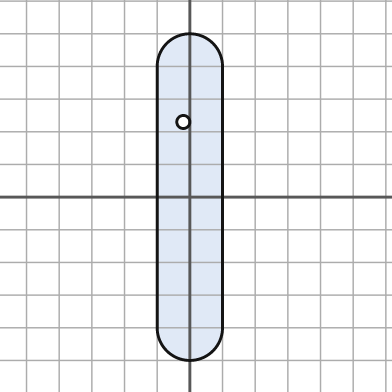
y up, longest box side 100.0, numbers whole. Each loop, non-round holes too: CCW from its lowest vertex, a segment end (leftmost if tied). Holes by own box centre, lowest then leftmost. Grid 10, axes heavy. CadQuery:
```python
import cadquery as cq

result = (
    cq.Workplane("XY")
    .moveTo(-10.0, -40.0)
    .threePointArc((0.0, -50.0), (10.0, -40.0))
    .lineTo(10.0, 40.0)
    .threePointArc((0.0, 50.0), (-10.0, 40.0))
    .close()
    .moveTo(-2.0, 23.0)
    .circle(2.0)
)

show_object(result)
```